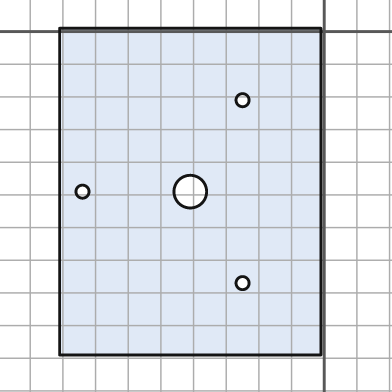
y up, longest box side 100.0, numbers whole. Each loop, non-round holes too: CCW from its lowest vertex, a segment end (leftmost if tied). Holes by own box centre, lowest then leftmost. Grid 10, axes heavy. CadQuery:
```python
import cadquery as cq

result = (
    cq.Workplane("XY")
    .moveTo(-81.0, -99.0)
    .lineTo(-1.0, -99.0)
    .lineTo(-1.0, 1.0)
    .lineTo(-81.0, 1.0)
    .close()
    .moveTo(-25.0, -77.0)
    .circle(2.0)
    .moveTo(-74.0, -49.0)
    .circle(2.0)
    .moveTo(-41.0, -49.0)
    .circle(5.0)
    .moveTo(-25.0, -21.0)
    .circle(2.0)
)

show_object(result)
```